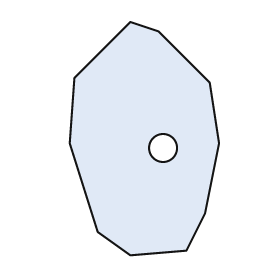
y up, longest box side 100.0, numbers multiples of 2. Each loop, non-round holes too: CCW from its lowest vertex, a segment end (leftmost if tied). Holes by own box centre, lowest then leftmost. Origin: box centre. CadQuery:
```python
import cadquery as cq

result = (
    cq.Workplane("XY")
    .moveTo(-6.0, -50.0)
    .lineTo(18.0, -48.0)
    .lineTo(26.0, -32.0)
    .lineTo(32.0, -2.0)
    .lineTo(28.0, 24.0)
    .lineTo(6.0, 46.0)
    .lineTo(-6.0, 50.0)
    .lineTo(-30.0, 26.0)
    .lineTo(-32.0, -2.0)
    .lineTo(-20.0, -40.0)
    .close()
    .moveTo(8.0, -4.0)
    .circle(6.0)
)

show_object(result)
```